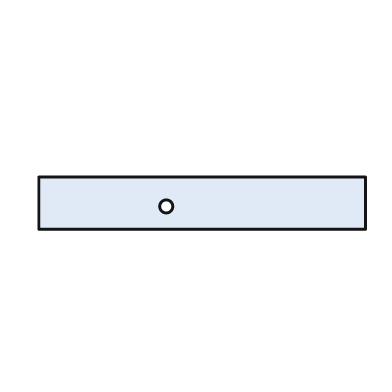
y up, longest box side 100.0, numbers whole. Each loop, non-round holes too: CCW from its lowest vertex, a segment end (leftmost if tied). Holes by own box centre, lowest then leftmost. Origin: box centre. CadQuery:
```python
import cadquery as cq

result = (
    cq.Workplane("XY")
    .moveTo(-50.0, -8.0)
    .lineTo(50.0, -8.0)
    .lineTo(50.0, 8.0)
    .lineTo(-50.0, 8.0)
    .close()
    .moveTo(-11.0, -1.0)
    .circle(2.0)
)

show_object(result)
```